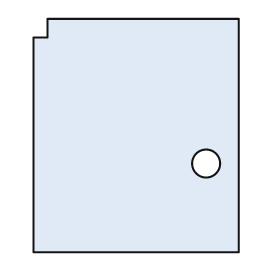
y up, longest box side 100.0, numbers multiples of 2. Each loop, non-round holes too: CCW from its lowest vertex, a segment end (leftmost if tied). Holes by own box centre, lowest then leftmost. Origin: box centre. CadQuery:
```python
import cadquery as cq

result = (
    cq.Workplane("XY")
    .moveTo(-44.0, -50.0)
    .lineTo(44.0, -50.0)
    .lineTo(44.0, 50.0)
    .lineTo(-38.0, 50.0)
    .lineTo(-38.0, 42.0)
    .lineTo(-44.0, 42.0)
    .close()
    .moveTo(30.0, -12.0)
    .circle(6.0)
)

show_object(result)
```